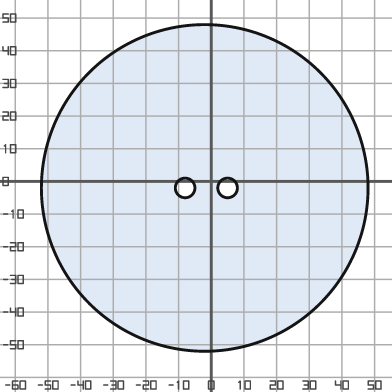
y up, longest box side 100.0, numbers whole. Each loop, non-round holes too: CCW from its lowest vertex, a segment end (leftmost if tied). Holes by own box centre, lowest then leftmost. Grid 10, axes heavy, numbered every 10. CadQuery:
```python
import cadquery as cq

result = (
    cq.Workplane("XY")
    .moveTo(-2.0, -2.0)
    .circle(50.0)
    .moveTo(-8.0, -2.0)
    .circle(3.0)
    .moveTo(5.0, -2.0)
    .circle(3.0)
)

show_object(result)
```